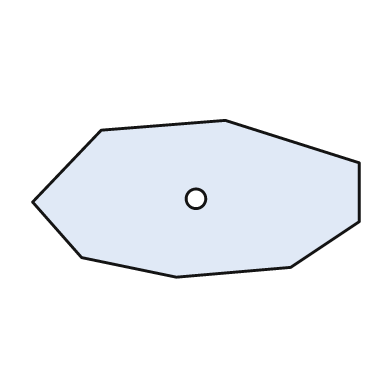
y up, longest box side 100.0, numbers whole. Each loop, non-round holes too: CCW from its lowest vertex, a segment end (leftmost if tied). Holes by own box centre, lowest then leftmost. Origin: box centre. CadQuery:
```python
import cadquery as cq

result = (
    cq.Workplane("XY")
    .moveTo(-6.0, -24.0)
    .lineTo(29.0, -21.0)
    .lineTo(50.0, -7.0)
    .lineTo(50.0, 11.0)
    .lineTo(9.0, 24.0)
    .lineTo(-29.0, 21.0)
    .lineTo(-50.0, -1.0)
    .lineTo(-35.0, -18.0)
    .close()
    .moveTo(0.0, 0.0)
    .circle(3.0)
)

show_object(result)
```